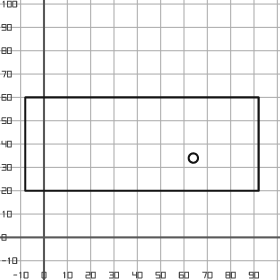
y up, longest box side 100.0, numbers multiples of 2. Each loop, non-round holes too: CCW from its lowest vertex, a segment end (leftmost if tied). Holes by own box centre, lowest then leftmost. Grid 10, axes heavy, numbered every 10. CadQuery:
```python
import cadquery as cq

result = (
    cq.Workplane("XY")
    .moveTo(-8.0, 20.0)
    .lineTo(92.0, 20.0)
    .lineTo(92.0, 60.0)
    .lineTo(-8.0, 60.0)
    .close()
    .moveTo(64.0, 34.0)
    .circle(2.0)
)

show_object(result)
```